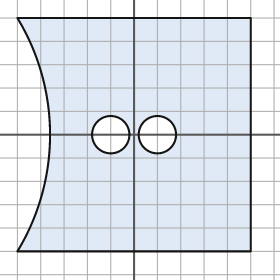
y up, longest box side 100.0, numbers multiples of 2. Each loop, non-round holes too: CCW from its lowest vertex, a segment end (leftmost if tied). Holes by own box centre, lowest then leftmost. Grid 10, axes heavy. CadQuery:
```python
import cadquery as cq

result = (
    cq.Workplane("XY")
    .moveTo(-50.0, -50.0)
    .lineTo(50.0, -50.0)
    .lineTo(50.0, 50.0)
    .lineTo(-50.0, 50.0)
    .threePointArc((-36.0, 0.0), (-50.0, -50.0))
    .close()
    .moveTo(-10.0, 0.0)
    .circle(8.0)
    .moveTo(10.0, 0.0)
    .circle(8.0)
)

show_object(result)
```